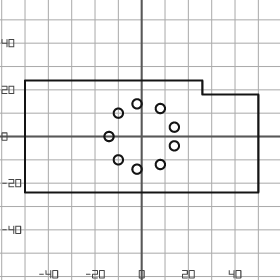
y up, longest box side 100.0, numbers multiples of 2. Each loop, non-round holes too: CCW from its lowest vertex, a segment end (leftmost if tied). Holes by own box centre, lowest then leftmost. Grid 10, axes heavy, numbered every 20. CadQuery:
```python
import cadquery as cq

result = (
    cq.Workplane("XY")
    .moveTo(-50.0, -24.0)
    .lineTo(50.0, -24.0)
    .lineTo(50.0, 18.0)
    .lineTo(26.0, 18.0)
    .lineTo(26.0, 24.0)
    .lineTo(-50.0, 24.0)
    .close()
    .moveTo(-2.0, -14.0)
    .circle(2.0)
    .moveTo(8.0, -12.0)
    .circle(2.0)
    .moveTo(-10.0, -10.0)
    .circle(2.0)
    .moveTo(14.0, -4.0)
    .circle(2.0)
    .moveTo(-14.0, 0.0)
    .circle(2.0)
    .moveTo(14.0, 4.0)
    .circle(2.0)
    .moveTo(-10.0, 10.0)
    .circle(2.0)
    .moveTo(8.0, 12.0)
    .circle(2.0)
    .moveTo(-2.0, 14.0)
    .circle(2.0)
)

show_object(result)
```